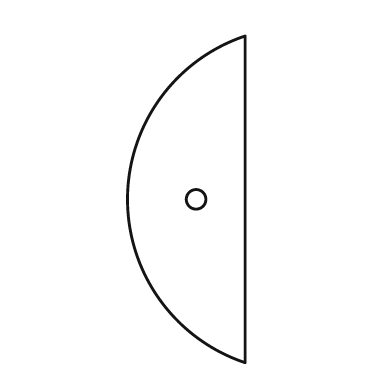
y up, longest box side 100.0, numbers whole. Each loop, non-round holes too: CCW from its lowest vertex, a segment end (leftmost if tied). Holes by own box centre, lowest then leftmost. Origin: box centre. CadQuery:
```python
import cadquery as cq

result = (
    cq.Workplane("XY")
    .moveTo(18.0, -50.0)
    .lineTo(18.0, 50.0)
    .threePointArc((-18.0, 0.0), (18.0, -50.0))
    .close()
    .moveTo(3.0, 0.0)
    .circle(3.0)
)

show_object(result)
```